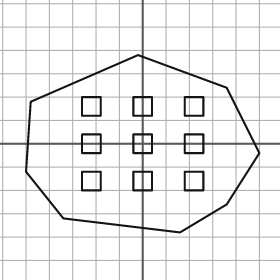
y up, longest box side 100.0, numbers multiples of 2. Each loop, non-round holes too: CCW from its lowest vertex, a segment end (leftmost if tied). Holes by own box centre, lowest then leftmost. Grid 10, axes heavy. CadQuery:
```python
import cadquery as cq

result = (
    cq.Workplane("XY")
    .moveTo(16.0, -38.0)
    .lineTo(36.0, -26.0)
    .lineTo(50.0, -4.0)
    .lineTo(36.0, 24.0)
    .lineTo(-2.0, 38.0)
    .lineTo(-48.0, 18.0)
    .lineTo(-50.0, -12.0)
    .lineTo(-34.0, -32.0)
    .close()
    .moveTo(-26.0, -20.0)
    .lineTo(-18.0, -20.0)
    .lineTo(-18.0, -12.0)
    .lineTo(-26.0, -12.0)
    .close()
    .moveTo(-4.0, -20.0)
    .lineTo(4.0, -20.0)
    .lineTo(4.0, -12.0)
    .lineTo(-4.0, -12.0)
    .close()
    .moveTo(18.0, -20.0)
    .lineTo(26.0, -20.0)
    .lineTo(26.0, -12.0)
    .lineTo(18.0, -12.0)
    .close()
    .moveTo(-26.0, -4.0)
    .lineTo(-18.0, -4.0)
    .lineTo(-18.0, 4.0)
    .lineTo(-26.0, 4.0)
    .close()
    .moveTo(-4.0, -4.0)
    .lineTo(4.0, -4.0)
    .lineTo(4.0, 4.0)
    .lineTo(-4.0, 4.0)
    .close()
    .moveTo(18.0, -4.0)
    .lineTo(26.0, -4.0)
    .lineTo(26.0, 4.0)
    .lineTo(18.0, 4.0)
    .close()
    .moveTo(-26.0, 12.0)
    .lineTo(-18.0, 12.0)
    .lineTo(-18.0, 20.0)
    .lineTo(-26.0, 20.0)
    .close()
    .moveTo(-4.0, 12.0)
    .lineTo(4.0, 12.0)
    .lineTo(4.0, 20.0)
    .lineTo(-4.0, 20.0)
    .close()
    .moveTo(18.0, 12.0)
    .lineTo(26.0, 12.0)
    .lineTo(26.0, 20.0)
    .lineTo(18.0, 20.0)
    .close()
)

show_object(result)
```